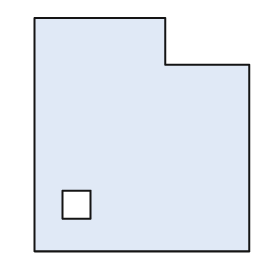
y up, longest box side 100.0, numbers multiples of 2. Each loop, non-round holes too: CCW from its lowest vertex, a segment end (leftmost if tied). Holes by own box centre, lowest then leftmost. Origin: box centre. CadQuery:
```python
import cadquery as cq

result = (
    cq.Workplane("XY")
    .moveTo(-46.0, -50.0)
    .lineTo(46.0, -50.0)
    .lineTo(46.0, 30.0)
    .lineTo(10.0, 30.0)
    .lineTo(10.0, 50.0)
    .lineTo(-46.0, 50.0)
    .close()
    .moveTo(-34.0, -36.0)
    .lineTo(-22.0, -36.0)
    .lineTo(-22.0, -24.0)
    .lineTo(-34.0, -24.0)
    .close()
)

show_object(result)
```